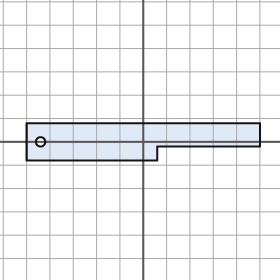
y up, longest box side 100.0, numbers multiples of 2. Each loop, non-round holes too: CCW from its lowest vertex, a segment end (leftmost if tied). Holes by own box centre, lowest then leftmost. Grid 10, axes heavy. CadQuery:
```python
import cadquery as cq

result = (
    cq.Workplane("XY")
    .moveTo(-50.0, -8.0)
    .lineTo(6.0, -8.0)
    .lineTo(6.0, -2.0)
    .lineTo(50.0, -2.0)
    .lineTo(50.0, 8.0)
    .lineTo(-50.0, 8.0)
    .close()
    .moveTo(-44.0, 0.0)
    .circle(2.0)
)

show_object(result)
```